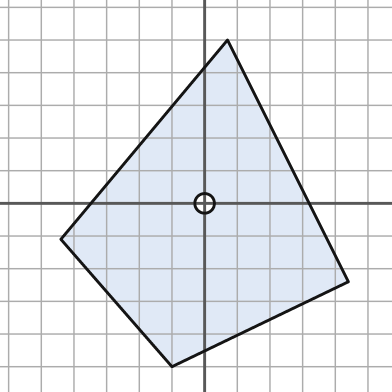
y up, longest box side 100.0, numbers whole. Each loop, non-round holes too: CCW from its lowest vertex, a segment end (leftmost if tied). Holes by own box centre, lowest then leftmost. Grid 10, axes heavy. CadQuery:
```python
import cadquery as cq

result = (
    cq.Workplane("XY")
    .moveTo(-10.0, -50.0)
    .lineTo(44.0, -24.0)
    .lineTo(7.0, 50.0)
    .lineTo(-44.0, -11.0)
    .close()
    .moveTo(0.0, 0.0)
    .circle(3.0)
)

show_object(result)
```